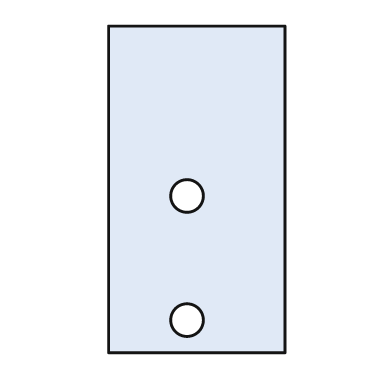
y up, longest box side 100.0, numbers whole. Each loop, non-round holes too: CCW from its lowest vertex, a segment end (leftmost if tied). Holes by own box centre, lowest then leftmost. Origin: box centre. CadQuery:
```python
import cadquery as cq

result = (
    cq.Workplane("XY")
    .moveTo(-27.0, -50.0)
    .lineTo(27.0, -50.0)
    .lineTo(27.0, 50.0)
    .lineTo(-27.0, 50.0)
    .close()
    .moveTo(-3.0, -40.0)
    .circle(5.0)
    .moveTo(-3.0, -2.0)
    .circle(5.0)
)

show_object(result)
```